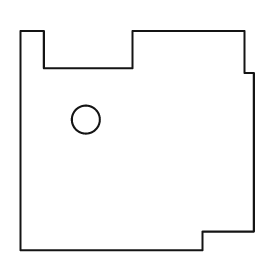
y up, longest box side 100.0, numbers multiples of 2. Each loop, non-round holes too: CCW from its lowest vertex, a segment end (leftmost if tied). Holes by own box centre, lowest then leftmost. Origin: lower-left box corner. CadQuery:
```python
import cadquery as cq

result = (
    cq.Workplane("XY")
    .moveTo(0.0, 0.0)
    .lineTo(78.0, 0.0)
    .lineTo(78.0, 8.0)
    .lineTo(100.0, 8.0)
    .lineTo(100.0, 76.0)
    .lineTo(96.0, 76.0)
    .lineTo(96.0, 94.0)
    .lineTo(48.0, 94.0)
    .lineTo(48.0, 78.0)
    .lineTo(10.0, 78.0)
    .lineTo(10.0, 94.0)
    .lineTo(0.0, 94.0)
    .close()
    .moveTo(28.0, 56.0)
    .circle(6.0)
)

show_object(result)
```